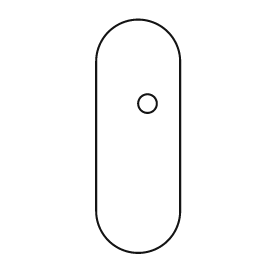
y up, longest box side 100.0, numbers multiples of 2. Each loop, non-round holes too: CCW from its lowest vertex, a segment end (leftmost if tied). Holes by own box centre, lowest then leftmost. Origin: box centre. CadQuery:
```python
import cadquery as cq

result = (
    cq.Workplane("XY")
    .moveTo(-18.0, -32.0)
    .threePointArc((0.0, -50.0), (18.0, -32.0))
    .lineTo(18.0, 32.0)
    .threePointArc((0.0, 50.0), (-18.0, 32.0))
    .close()
    .moveTo(4.0, 14.0)
    .circle(4.0)
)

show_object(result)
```